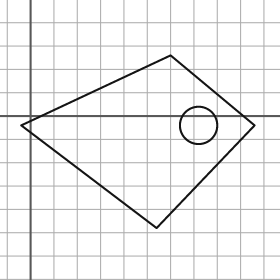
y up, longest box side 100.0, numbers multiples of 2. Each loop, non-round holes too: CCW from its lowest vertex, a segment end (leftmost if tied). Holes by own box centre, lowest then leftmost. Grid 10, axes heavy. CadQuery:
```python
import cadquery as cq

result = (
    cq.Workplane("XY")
    .moveTo(54.0, -48.0)
    .lineTo(96.0, -4.0)
    .lineTo(60.0, 26.0)
    .lineTo(-4.0, -4.0)
    .close()
    .moveTo(72.0, -4.0)
    .circle(8.0)
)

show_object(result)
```